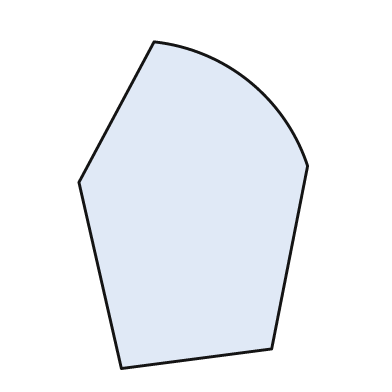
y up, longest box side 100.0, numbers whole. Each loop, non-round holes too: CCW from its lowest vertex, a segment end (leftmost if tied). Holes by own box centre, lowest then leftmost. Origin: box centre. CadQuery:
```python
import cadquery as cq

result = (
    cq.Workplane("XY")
    .moveTo(-22.0, -50.0)
    .lineTo(24.0, -44.0)
    .lineTo(35.0, 12.0)
    .threePointArc((17.0, 38.0), (-12.0, 50.0))
    .lineTo(-35.0, 7.0)
    .close()
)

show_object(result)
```